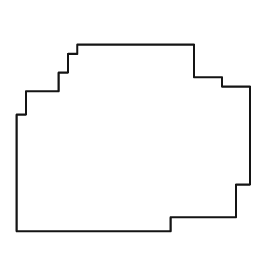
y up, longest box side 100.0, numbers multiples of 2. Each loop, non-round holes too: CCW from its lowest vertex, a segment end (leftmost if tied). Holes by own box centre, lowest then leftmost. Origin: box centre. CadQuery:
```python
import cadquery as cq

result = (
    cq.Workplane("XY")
    .moveTo(-50.0, -40.0)
    .lineTo(16.0, -40.0)
    .lineTo(16.0, -34.0)
    .lineTo(44.0, -34.0)
    .lineTo(44.0, -20.0)
    .lineTo(50.0, -20.0)
    .lineTo(50.0, 22.0)
    .lineTo(38.0, 22.0)
    .lineTo(38.0, 26.0)
    .lineTo(26.0, 26.0)
    .lineTo(26.0, 40.0)
    .lineTo(-24.0, 40.0)
    .lineTo(-24.0, 36.0)
    .lineTo(-28.0, 36.0)
    .lineTo(-28.0, 28.0)
    .lineTo(-32.0, 28.0)
    .lineTo(-32.0, 20.0)
    .lineTo(-46.0, 20.0)
    .lineTo(-46.0, 10.0)
    .lineTo(-50.0, 10.0)
    .close()
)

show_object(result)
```